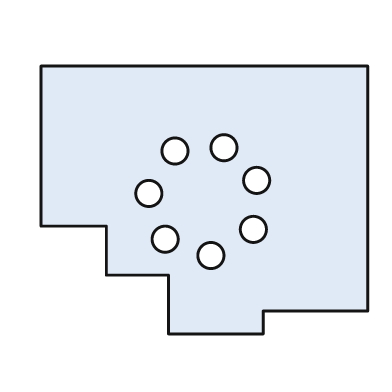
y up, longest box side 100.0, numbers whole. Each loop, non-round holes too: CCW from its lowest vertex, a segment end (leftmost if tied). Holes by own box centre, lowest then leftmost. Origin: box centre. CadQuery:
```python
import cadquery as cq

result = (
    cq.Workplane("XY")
    .moveTo(-11.0, -41.0)
    .lineTo(18.0, -41.0)
    .lineTo(18.0, -34.0)
    .lineTo(50.0, -34.0)
    .lineTo(50.0, 41.0)
    .lineTo(-50.0, 41.0)
    .lineTo(-50.0, -8.0)
    .lineTo(-30.0, -8.0)
    .lineTo(-30.0, -23.0)
    .lineTo(-11.0, -23.0)
    .close()
    .moveTo(2.0, -17.0)
    .circle(4.0)
    .moveTo(-12.0, -12.0)
    .circle(4.0)
    .moveTo(15.0, -9.0)
    .circle(4.0)
    .moveTo(-17.0, 2.0)
    .circle(4.0)
    .moveTo(16.0, 6.0)
    .circle(4.0)
    .moveTo(-9.0, 15.0)
    .circle(4.0)
    .moveTo(6.0, 16.0)
    .circle(4.0)
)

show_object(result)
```